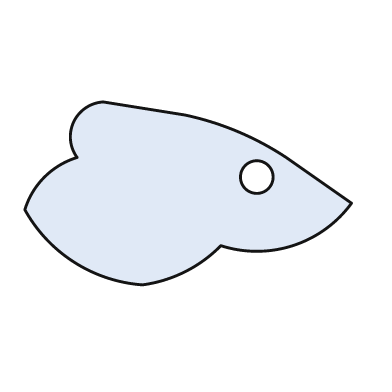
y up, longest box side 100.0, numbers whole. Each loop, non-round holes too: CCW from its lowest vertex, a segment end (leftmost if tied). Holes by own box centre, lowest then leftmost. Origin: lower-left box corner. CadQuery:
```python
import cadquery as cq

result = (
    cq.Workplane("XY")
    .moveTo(36.0, 0.0)
    .threePointArc((49.0, 4.0), (60.0, 12.0))
    .threePointArc((82.0, 12.0), (100.0, 25.0))
    .lineTo(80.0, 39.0)
    .threePointArc((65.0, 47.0), (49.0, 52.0))
    .lineTo(24.0, 56.0)
    .threePointArc((15.0, 50.0), (16.0, 39.0))
    .threePointArc((6.0, 33.0), (0.0, 23.0))
    .threePointArc((15.0, 7.0), (36.0, 0.0))
    .close()
    .moveTo(71.0, 33.0)
    .circle(5.0)
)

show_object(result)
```